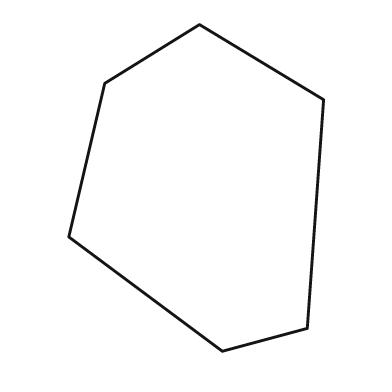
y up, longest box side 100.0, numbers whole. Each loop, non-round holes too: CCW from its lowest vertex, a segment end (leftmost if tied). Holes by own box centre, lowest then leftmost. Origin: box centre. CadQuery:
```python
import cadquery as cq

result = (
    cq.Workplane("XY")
    .moveTo(8.0, -50.0)
    .lineTo(34.0, -43.0)
    .lineTo(39.0, 27.0)
    .lineTo(1.0, 50.0)
    .lineTo(-28.0, 32.0)
    .lineTo(-39.0, -15.0)
    .close()
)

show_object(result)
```